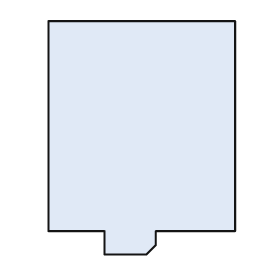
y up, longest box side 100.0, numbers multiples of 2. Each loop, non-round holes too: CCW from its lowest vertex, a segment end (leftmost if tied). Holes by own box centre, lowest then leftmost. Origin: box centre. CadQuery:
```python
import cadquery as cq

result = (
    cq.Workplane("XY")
    .moveTo(-16.0, -50.0)
    .lineTo(2.0, -50.0)
    .lineTo(6.0, -46.0)
    .lineTo(6.0, -40.0)
    .lineTo(40.0, -40.0)
    .lineTo(40.0, 50.0)
    .lineTo(-40.0, 50.0)
    .lineTo(-40.0, -40.0)
    .lineTo(-16.0, -40.0)
    .close()
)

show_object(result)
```